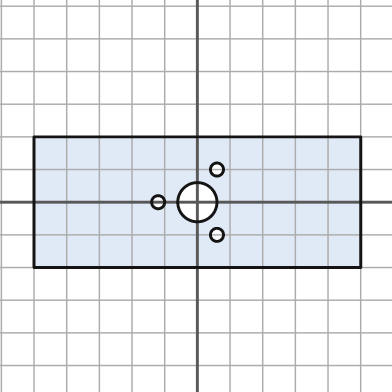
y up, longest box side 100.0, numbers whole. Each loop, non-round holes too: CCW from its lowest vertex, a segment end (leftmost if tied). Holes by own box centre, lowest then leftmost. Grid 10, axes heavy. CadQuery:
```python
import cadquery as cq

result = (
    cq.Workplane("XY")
    .moveTo(-50.0, -20.0)
    .lineTo(50.0, -20.0)
    .lineTo(50.0, 20.0)
    .lineTo(-50.0, 20.0)
    .close()
    .moveTo(6.0, -10.0)
    .circle(2.0)
    .moveTo(-12.0, 0.0)
    .circle(2.0)
    .moveTo(0.0, 0.0)
    .circle(6.0)
    .moveTo(6.0, 10.0)
    .circle(2.0)
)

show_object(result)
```